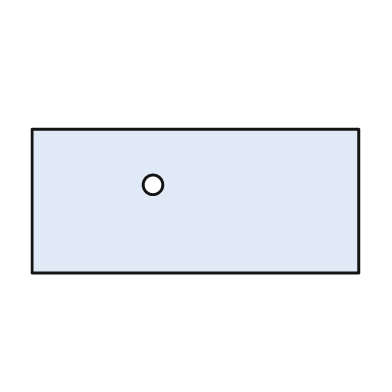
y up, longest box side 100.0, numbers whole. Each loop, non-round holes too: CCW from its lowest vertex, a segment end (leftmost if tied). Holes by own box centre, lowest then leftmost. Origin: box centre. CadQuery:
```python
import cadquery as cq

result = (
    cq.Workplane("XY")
    .moveTo(-50.0, -22.0)
    .lineTo(50.0, -22.0)
    .lineTo(50.0, 22.0)
    .lineTo(-50.0, 22.0)
    .close()
    .moveTo(-13.0, 5.0)
    .circle(3.0)
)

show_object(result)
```